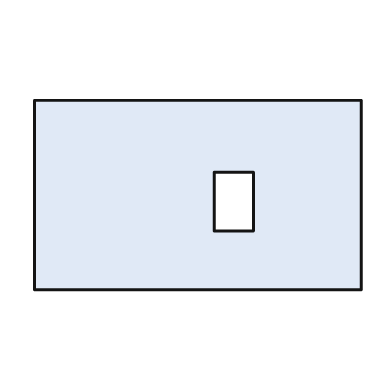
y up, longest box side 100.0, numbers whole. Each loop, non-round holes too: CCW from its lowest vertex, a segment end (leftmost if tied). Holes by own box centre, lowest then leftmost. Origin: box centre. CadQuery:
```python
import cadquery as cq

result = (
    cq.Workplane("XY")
    .moveTo(-50.0, -29.0)
    .lineTo(50.0, -29.0)
    .lineTo(50.0, 29.0)
    .lineTo(-50.0, 29.0)
    .close()
    .moveTo(5.0, -11.0)
    .lineTo(17.0, -11.0)
    .lineTo(17.0, 7.0)
    .lineTo(5.0, 7.0)
    .close()
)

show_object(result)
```